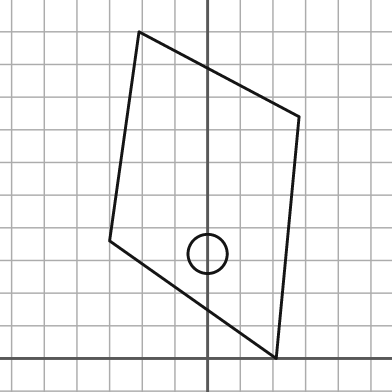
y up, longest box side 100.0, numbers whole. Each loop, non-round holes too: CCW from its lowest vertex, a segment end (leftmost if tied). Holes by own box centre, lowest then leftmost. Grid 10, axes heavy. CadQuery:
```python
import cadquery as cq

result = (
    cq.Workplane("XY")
    .moveTo(21.0, 0.0)
    .lineTo(28.0, 74.0)
    .lineTo(-21.0, 100.0)
    .lineTo(-30.0, 36.0)
    .close()
    .moveTo(0.0, 32.0)
    .circle(6.0)
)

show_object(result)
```